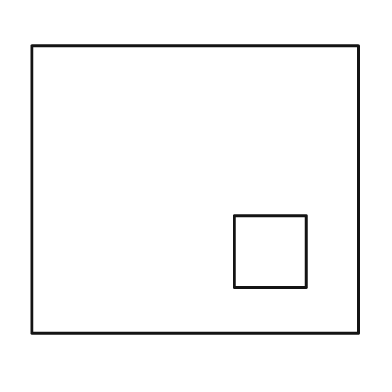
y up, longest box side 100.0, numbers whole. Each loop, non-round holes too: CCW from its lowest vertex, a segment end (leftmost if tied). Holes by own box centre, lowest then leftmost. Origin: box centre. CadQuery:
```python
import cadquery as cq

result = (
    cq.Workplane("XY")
    .moveTo(-50.0, -44.0)
    .lineTo(50.0, -44.0)
    .lineTo(50.0, 44.0)
    .lineTo(-50.0, 44.0)
    .close()
    .moveTo(12.0, -30.0)
    .lineTo(34.0, -30.0)
    .lineTo(34.0, -8.0)
    .lineTo(12.0, -8.0)
    .close()
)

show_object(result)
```